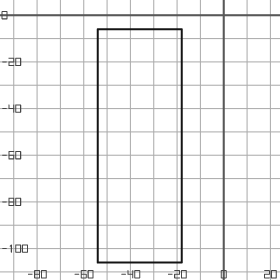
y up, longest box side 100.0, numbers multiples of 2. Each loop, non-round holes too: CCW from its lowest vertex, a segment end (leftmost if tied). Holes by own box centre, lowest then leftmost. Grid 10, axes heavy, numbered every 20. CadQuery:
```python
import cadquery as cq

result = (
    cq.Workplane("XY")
    .moveTo(-54.0, -106.0)
    .lineTo(-18.0, -106.0)
    .lineTo(-18.0, -6.0)
    .lineTo(-54.0, -6.0)
    .close()
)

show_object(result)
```